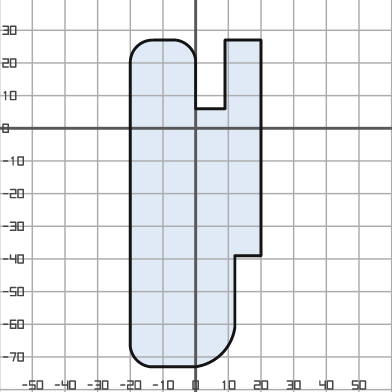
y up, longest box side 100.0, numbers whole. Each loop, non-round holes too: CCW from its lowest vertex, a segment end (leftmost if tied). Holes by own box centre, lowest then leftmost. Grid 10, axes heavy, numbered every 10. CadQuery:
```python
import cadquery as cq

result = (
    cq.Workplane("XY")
    .moveTo(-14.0, -73.0)
    .lineTo(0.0, -73.0)
    .threePointArc((8.0, -69.0), (12.0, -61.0))
    .lineTo(12.0, -39.0)
    .lineTo(20.0, -39.0)
    .lineTo(20.0, 27.0)
    .lineTo(9.0, 27.0)
    .lineTo(9.0, 6.0)
    .lineTo(0.0, 6.0)
    .lineTo(0.0, 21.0)
    .threePointArc((-2.0, 25.0), (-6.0, 27.0))
    .lineTo(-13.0, 27.0)
    .threePointArc((-18.0, 25.0), (-20.0, 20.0))
    .lineTo(-20.0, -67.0)
    .threePointArc((-18.0, -71.0), (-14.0, -73.0))
    .close()
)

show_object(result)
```